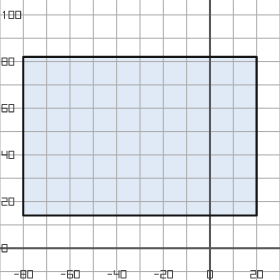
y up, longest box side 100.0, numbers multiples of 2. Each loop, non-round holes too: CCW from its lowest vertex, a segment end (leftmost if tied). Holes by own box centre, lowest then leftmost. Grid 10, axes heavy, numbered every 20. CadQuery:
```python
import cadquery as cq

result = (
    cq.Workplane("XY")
    .moveTo(-80.0, 14.0)
    .lineTo(20.0, 14.0)
    .lineTo(20.0, 82.0)
    .lineTo(-80.0, 82.0)
    .close()
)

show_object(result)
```